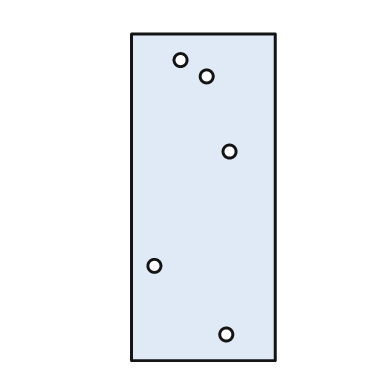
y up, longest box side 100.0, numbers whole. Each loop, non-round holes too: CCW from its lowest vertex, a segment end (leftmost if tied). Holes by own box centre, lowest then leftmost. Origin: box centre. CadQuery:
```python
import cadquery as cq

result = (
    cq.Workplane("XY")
    .moveTo(-22.0, -50.0)
    .lineTo(22.0, -50.0)
    .lineTo(22.0, 50.0)
    .lineTo(-22.0, 50.0)
    .close()
    .moveTo(7.0, -42.0)
    .circle(2.0)
    .moveTo(-15.0, -21.0)
    .circle(2.0)
    .moveTo(8.0, 14.0)
    .circle(2.0)
    .moveTo(1.0, 37.0)
    .circle(2.0)
    .moveTo(-7.0, 42.0)
    .circle(2.0)
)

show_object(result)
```